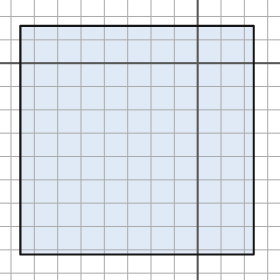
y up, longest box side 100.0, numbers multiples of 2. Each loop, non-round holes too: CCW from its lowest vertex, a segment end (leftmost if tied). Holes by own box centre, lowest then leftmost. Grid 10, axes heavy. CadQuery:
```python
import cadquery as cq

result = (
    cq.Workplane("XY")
    .moveTo(-76.0, -82.0)
    .lineTo(24.0, -82.0)
    .lineTo(24.0, 16.0)
    .lineTo(-76.0, 16.0)
    .close()
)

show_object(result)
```